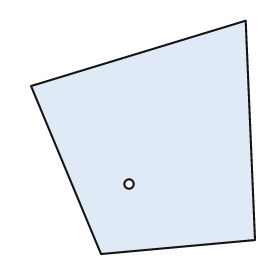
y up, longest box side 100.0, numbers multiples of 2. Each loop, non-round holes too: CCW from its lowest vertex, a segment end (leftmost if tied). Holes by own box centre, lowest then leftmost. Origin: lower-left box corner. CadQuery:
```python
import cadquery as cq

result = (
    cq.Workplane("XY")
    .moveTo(30.0, 0.0)
    .lineTo(96.0, 6.0)
    .lineTo(92.0, 100.0)
    .lineTo(0.0, 72.0)
    .close()
    .moveTo(42.0, 30.0)
    .circle(2.0)
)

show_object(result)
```